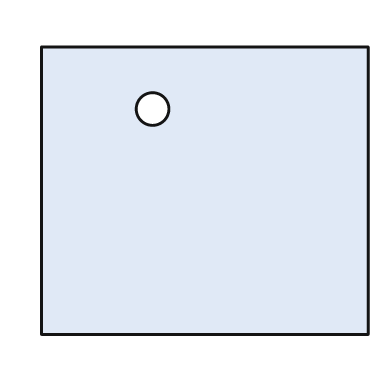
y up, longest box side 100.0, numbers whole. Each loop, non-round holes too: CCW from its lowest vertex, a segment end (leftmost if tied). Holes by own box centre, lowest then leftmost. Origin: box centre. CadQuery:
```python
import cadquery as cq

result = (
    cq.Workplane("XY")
    .moveTo(-50.0, -44.0)
    .lineTo(50.0, -44.0)
    .lineTo(50.0, 44.0)
    .lineTo(-50.0, 44.0)
    .close()
    .moveTo(-16.0, 25.0)
    .circle(5.0)
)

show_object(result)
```